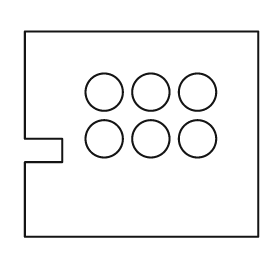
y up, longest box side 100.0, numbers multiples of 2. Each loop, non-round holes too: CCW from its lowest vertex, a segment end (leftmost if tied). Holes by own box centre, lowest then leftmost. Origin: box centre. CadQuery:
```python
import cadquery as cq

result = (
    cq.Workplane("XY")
    .moveTo(-50.0, -44.0)
    .lineTo(50.0, -44.0)
    .lineTo(50.0, 44.0)
    .lineTo(-50.0, 44.0)
    .lineTo(-50.0, -2.0)
    .lineTo(-34.0, -2.0)
    .lineTo(-34.0, -12.0)
    .lineTo(-50.0, -12.0)
    .close()
    .moveTo(-16.0, -2.0)
    .circle(8.0)
    .moveTo(4.0, -2.0)
    .circle(8.0)
    .moveTo(24.0, -2.0)
    .circle(8.0)
    .moveTo(-16.0, 18.0)
    .circle(8.0)
    .moveTo(4.0, 18.0)
    .circle(8.0)
    .moveTo(24.0, 18.0)
    .circle(8.0)
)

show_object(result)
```